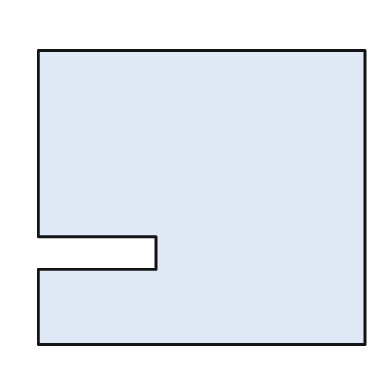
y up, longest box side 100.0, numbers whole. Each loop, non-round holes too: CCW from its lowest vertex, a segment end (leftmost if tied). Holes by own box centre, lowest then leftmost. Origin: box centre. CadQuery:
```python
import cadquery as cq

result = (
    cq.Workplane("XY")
    .moveTo(-50.0, -45.0)
    .lineTo(50.0, -45.0)
    .lineTo(50.0, 45.0)
    .lineTo(-50.0, 45.0)
    .lineTo(-50.0, -12.0)
    .lineTo(-14.0, -12.0)
    .lineTo(-14.0, -22.0)
    .lineTo(-50.0, -22.0)
    .close()
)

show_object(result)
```